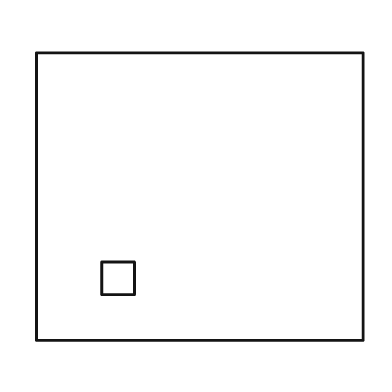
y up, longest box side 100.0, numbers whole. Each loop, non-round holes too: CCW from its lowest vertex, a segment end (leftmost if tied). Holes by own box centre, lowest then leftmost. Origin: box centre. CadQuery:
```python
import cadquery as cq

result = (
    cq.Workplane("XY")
    .moveTo(-50.0, -44.0)
    .lineTo(50.0, -44.0)
    .lineTo(50.0, 44.0)
    .lineTo(-50.0, 44.0)
    .close()
    .moveTo(-30.0, -30.0)
    .lineTo(-20.0, -30.0)
    .lineTo(-20.0, -20.0)
    .lineTo(-30.0, -20.0)
    .close()
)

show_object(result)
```